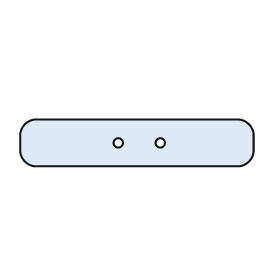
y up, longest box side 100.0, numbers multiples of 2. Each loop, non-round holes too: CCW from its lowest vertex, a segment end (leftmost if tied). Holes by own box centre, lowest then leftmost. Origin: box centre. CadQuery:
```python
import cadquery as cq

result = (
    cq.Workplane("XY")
    .moveTo(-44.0, -10.0)
    .lineTo(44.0, -10.0)
    .threePointArc((48.0, -8.0), (50.0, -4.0))
    .lineTo(50.0, 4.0)
    .threePointArc((48.0, 8.0), (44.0, 10.0))
    .lineTo(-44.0, 10.0)
    .threePointArc((-48.0, 8.0), (-50.0, 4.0))
    .lineTo(-50.0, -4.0)
    .threePointArc((-48.0, -8.0), (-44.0, -10.0))
    .close()
    .moveTo(-8.0, 0.0)
    .circle(2.0)
    .moveTo(10.0, 0.0)
    .circle(2.0)
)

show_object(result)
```